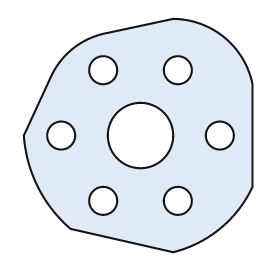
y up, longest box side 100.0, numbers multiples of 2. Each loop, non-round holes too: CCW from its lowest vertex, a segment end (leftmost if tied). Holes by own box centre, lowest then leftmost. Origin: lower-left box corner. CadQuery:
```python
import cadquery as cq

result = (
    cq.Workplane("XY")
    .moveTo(64.0, 0.0)
    .threePointArc((84.0, 10.0), (98.0, 28.0))
    .lineTo(98.0, 72.0)
    .threePointArc((86.0, 92.0), (64.0, 100.0))
    .lineTo(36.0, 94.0)
    .threePointArc((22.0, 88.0), (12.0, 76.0))
    .lineTo(0.0, 50.0)
    .threePointArc((6.0, 28.0), (20.0, 10.0))
    .close()
    .moveTo(34.0, 22.0)
    .circle(6.0)
    .moveTo(66.0, 22.0)
    .circle(6.0)
    .moveTo(16.0, 50.0)
    .circle(6.0)
    .moveTo(50.0, 50.0)
    .circle(14.0)
    .moveTo(84.0, 50.0)
    .circle(6.0)
    .moveTo(34.0, 78.0)
    .circle(6.0)
    .moveTo(66.0, 78.0)
    .circle(6.0)
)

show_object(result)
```